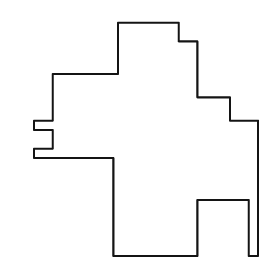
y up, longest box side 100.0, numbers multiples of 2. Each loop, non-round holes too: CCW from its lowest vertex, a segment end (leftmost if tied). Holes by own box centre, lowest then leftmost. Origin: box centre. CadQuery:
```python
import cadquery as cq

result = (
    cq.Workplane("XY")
    .moveTo(-14.0, -50.0)
    .lineTo(22.0, -50.0)
    .lineTo(22.0, -26.0)
    .lineTo(44.0, -26.0)
    .lineTo(44.0, -50.0)
    .lineTo(48.0, -50.0)
    .lineTo(48.0, 8.0)
    .lineTo(36.0, 8.0)
    .lineTo(36.0, 18.0)
    .lineTo(22.0, 18.0)
    .lineTo(22.0, 42.0)
    .lineTo(14.0, 42.0)
    .lineTo(14.0, 50.0)
    .lineTo(-12.0, 50.0)
    .lineTo(-12.0, 28.0)
    .lineTo(-40.0, 28.0)
    .lineTo(-40.0, 8.0)
    .lineTo(-48.0, 8.0)
    .lineTo(-48.0, 4.0)
    .lineTo(-40.0, 4.0)
    .lineTo(-40.0, -4.0)
    .lineTo(-48.0, -4.0)
    .lineTo(-48.0, -8.0)
    .lineTo(-14.0, -8.0)
    .close()
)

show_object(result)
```